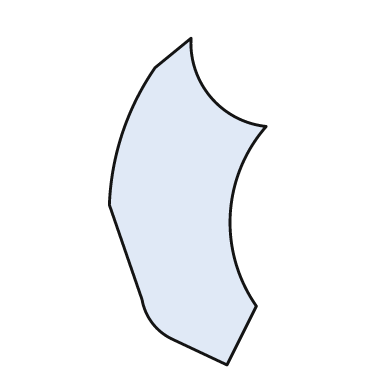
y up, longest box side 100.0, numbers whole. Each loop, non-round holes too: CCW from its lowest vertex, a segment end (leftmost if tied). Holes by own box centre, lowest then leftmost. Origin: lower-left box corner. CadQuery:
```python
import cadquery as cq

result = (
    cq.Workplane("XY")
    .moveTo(36.0, 0.0)
    .lineTo(45.0, 18.0)
    .threePointArc((37.0, 46.0), (48.0, 73.0))
    .threePointArc((31.0, 82.0), (25.0, 100.0))
    .lineTo(14.0, 91.0)
    .threePointArc((4.0, 71.0), (0.0, 49.0))
    .lineTo(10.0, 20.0)
    .threePointArc((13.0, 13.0), (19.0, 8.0))
    .close()
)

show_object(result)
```